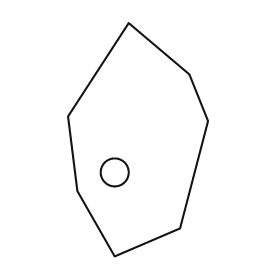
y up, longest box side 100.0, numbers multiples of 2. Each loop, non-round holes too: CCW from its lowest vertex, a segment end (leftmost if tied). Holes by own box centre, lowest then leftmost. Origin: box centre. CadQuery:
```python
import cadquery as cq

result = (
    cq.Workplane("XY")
    .moveTo(-10.0, -50.0)
    .lineTo(18.0, -38.0)
    .lineTo(30.0, 8.0)
    .lineTo(22.0, 28.0)
    .lineTo(-4.0, 50.0)
    .lineTo(-30.0, 10.0)
    .lineTo(-26.0, -22.0)
    .close()
    .moveTo(-10.0, -14.0)
    .circle(6.0)
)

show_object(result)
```